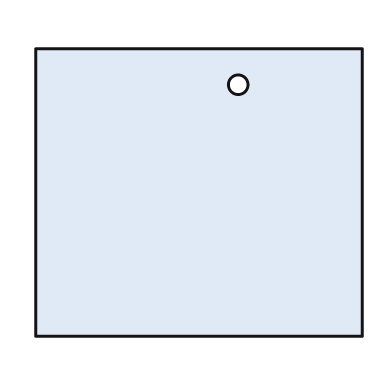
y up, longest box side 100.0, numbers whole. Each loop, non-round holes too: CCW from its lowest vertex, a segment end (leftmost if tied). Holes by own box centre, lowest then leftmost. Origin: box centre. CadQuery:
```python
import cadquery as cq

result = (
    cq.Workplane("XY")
    .moveTo(-50.0, -44.0)
    .lineTo(50.0, -44.0)
    .lineTo(50.0, 44.0)
    .lineTo(-50.0, 44.0)
    .close()
    .moveTo(12.0, 33.0)
    .circle(3.0)
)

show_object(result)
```